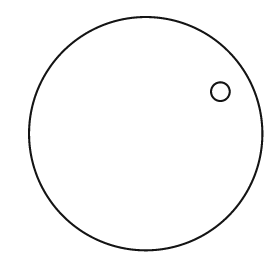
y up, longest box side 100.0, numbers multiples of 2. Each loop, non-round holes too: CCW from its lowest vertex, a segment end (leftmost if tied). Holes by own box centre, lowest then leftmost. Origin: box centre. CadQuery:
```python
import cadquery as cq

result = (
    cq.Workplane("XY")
    .moveTo(0.0, 0.0)
    .circle(50.0)
    .moveTo(32.0, 18.0)
    .circle(4.0)
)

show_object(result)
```